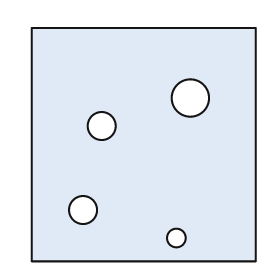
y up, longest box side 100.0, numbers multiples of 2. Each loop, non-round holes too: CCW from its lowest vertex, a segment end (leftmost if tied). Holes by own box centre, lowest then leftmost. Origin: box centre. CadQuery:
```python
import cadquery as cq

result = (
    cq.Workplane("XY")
    .moveTo(-48.0, -50.0)
    .lineTo(48.0, -50.0)
    .lineTo(48.0, 50.0)
    .lineTo(-48.0, 50.0)
    .close()
    .moveTo(14.0, -40.0)
    .circle(4.0)
    .moveTo(-26.0, -28.0)
    .circle(6.0)
    .moveTo(-18.0, 8.0)
    .circle(6.0)
    .moveTo(20.0, 20.0)
    .circle(8.0)
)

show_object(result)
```